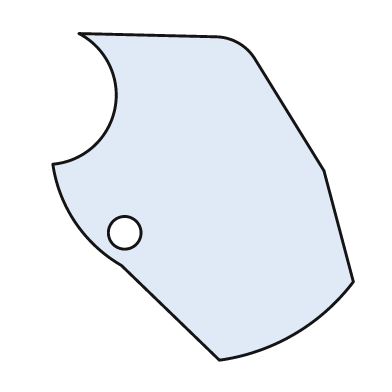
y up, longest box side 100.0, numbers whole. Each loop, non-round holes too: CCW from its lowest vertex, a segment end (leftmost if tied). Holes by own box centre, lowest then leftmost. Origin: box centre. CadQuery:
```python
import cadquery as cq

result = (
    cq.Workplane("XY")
    .moveTo(5.0, -50.0)
    .threePointArc((28.0, -42.0), (46.0, -26.0))
    .lineTo(37.0, 8.0)
    .lineTo(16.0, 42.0)
    .threePointArc((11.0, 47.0), (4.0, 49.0))
    .lineTo(-38.0, 50.0)
    .threePointArc((-27.0, 27.0), (-46.0, 10.0))
    .threePointArc((-39.0, -8.0), (-25.0, -21.0))
    .close()
    .moveTo(-24.0, -11.0)
    .circle(5.0)
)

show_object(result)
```